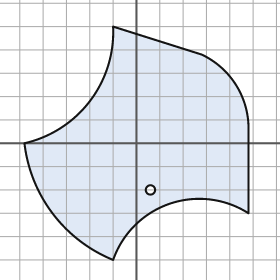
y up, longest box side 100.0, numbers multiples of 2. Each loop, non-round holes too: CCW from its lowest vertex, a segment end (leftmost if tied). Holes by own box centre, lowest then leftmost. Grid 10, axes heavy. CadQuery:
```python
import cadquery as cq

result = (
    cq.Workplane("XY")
    .moveTo(-10.0, -50.0)
    .threePointArc((14.0, -26.0), (48.0, -30.0))
    .lineTo(48.0, 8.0)
    .threePointArc((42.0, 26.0), (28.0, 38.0))
    .lineTo(-10.0, 50.0)
    .threePointArc((-20.0, 18.0), (-48.0, 0.0))
    .threePointArc((-36.0, -30.0), (-10.0, -50.0))
    .close()
    .moveTo(6.0, -20.0)
    .circle(2.0)
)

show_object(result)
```